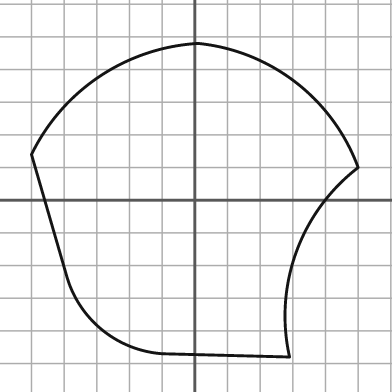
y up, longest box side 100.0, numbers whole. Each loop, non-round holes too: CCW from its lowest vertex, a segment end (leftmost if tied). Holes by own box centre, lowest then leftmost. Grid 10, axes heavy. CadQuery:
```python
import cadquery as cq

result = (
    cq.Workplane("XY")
    .moveTo(29.0, -48.0)
    .threePointArc((31.0, -16.0), (50.0, 10.0))
    .threePointArc((31.0, 36.0), (1.0, 48.0))
    .threePointArc((-29.0, 38.0), (-50.0, 14.0))
    .lineTo(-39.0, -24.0)
    .threePointArc((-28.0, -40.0), (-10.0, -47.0))
    .close()
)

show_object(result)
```